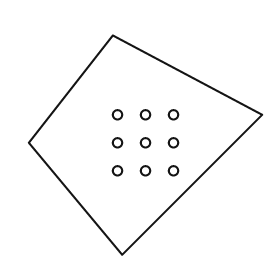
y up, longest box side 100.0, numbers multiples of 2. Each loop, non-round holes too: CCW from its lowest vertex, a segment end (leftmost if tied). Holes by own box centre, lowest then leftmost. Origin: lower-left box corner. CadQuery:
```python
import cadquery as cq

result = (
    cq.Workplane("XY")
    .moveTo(40.0, 0.0)
    .lineTo(100.0, 60.0)
    .lineTo(36.0, 94.0)
    .lineTo(0.0, 48.0)
    .close()
    .moveTo(38.0, 36.0)
    .circle(2.0)
    .moveTo(50.0, 36.0)
    .circle(2.0)
    .moveTo(62.0, 36.0)
    .circle(2.0)
    .moveTo(38.0, 48.0)
    .circle(2.0)
    .moveTo(50.0, 48.0)
    .circle(2.0)
    .moveTo(62.0, 48.0)
    .circle(2.0)
    .moveTo(38.0, 60.0)
    .circle(2.0)
    .moveTo(50.0, 60.0)
    .circle(2.0)
    .moveTo(62.0, 60.0)
    .circle(2.0)
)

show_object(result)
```